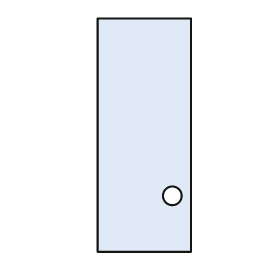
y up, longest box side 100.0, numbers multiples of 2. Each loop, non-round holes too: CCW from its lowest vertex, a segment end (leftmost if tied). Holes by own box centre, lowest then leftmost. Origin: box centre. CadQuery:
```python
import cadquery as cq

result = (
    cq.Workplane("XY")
    .moveTo(-20.0, -50.0)
    .lineTo(20.0, -50.0)
    .lineTo(20.0, 50.0)
    .lineTo(-20.0, 50.0)
    .close()
    .moveTo(12.0, -26.0)
    .circle(4.0)
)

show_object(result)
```